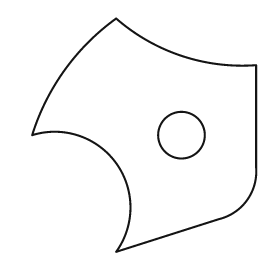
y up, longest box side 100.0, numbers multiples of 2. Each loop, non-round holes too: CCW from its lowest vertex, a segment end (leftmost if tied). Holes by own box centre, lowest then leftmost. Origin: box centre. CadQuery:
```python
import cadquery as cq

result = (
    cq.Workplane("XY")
    .moveTo(-12.0, -50.0)
    .lineTo(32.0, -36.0)
    .threePointArc((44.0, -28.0), (48.0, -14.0))
    .lineTo(48.0, 30.0)
    .threePointArc((16.0, 34.0), (-12.0, 50.0))
    .threePointArc((-34.0, 28.0), (-48.0, 0.0))
    .threePointArc((-12.0, -12.0), (-12.0, -50.0))
    .close()
    .moveTo(16.0, 0.0)
    .circle(10.0)
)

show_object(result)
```